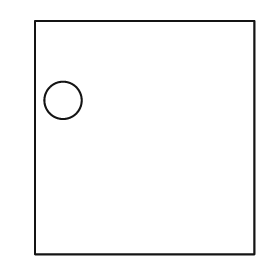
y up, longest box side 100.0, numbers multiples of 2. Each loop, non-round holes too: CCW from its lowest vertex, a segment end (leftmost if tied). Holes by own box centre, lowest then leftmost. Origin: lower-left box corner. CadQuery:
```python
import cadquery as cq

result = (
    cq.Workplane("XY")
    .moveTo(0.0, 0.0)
    .lineTo(94.0, 0.0)
    .lineTo(94.0, 100.0)
    .lineTo(0.0, 100.0)
    .close()
    .moveTo(12.0, 66.0)
    .circle(8.0)
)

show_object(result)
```